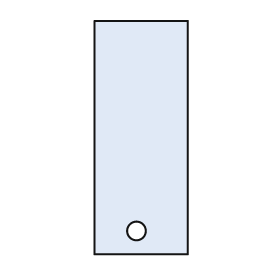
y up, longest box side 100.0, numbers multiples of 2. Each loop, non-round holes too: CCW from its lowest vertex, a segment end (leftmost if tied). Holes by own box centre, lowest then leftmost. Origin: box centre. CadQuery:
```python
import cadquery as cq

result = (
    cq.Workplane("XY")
    .moveTo(-20.0, -50.0)
    .lineTo(20.0, -50.0)
    .lineTo(20.0, 50.0)
    .lineTo(-20.0, 50.0)
    .close()
    .moveTo(-2.0, -40.0)
    .circle(4.0)
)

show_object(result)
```